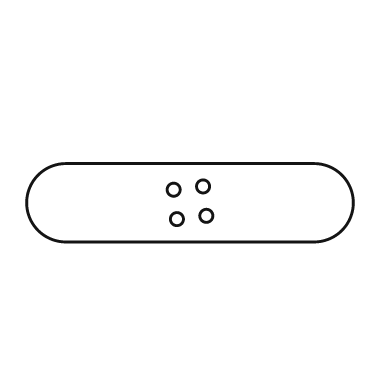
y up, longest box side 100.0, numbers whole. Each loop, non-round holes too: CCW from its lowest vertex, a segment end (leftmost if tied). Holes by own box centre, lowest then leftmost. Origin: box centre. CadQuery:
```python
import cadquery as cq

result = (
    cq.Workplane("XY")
    .moveTo(-38.0, -12.0)
    .lineTo(38.0, -12.0)
    .threePointArc((50.0, 0.0), (38.0, 12.0))
    .lineTo(-38.0, 12.0)
    .threePointArc((-50.0, 0.0), (-38.0, -12.0))
    .close()
    .moveTo(-4.0, -5.0)
    .circle(2.0)
    .moveTo(5.0, -4.0)
    .circle(2.0)
    .moveTo(-5.0, 4.0)
    .circle(2.0)
    .moveTo(4.0, 5.0)
    .circle(2.0)
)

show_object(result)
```